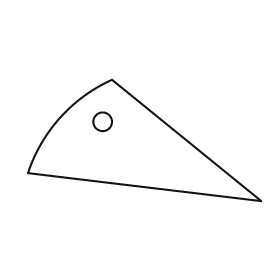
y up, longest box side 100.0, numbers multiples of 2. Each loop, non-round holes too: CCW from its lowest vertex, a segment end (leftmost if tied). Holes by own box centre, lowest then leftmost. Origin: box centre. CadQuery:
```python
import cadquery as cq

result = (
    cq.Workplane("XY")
    .moveTo(50.0, -26.0)
    .lineTo(-14.0, 26.0)
    .threePointArc((-36.0, 10.0), (-50.0, -14.0))
    .close()
    .moveTo(-18.0, 8.0)
    .circle(4.0)
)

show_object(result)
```